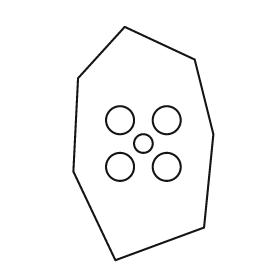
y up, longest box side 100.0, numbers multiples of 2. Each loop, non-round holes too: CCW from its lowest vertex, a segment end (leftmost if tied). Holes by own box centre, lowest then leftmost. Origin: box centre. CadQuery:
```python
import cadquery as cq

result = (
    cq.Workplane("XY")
    .moveTo(-12.0, -50.0)
    .lineTo(26.0, -36.0)
    .lineTo(30.0, 4.0)
    .lineTo(22.0, 36.0)
    .lineTo(-8.0, 50.0)
    .lineTo(-28.0, 28.0)
    .lineTo(-30.0, -12.0)
    .close()
    .moveTo(-10.0, -10.0)
    .circle(6.0)
    .moveTo(10.0, -10.0)
    .circle(6.0)
    .moveTo(0.0, 0.0)
    .circle(4.0)
    .moveTo(-10.0, 10.0)
    .circle(6.0)
    .moveTo(10.0, 10.0)
    .circle(6.0)
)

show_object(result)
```